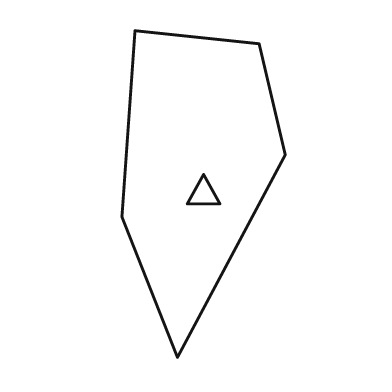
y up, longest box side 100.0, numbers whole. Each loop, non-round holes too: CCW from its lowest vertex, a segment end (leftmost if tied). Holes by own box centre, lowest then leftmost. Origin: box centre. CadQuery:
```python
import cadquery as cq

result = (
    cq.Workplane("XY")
    .moveTo(-8.0, -50.0)
    .lineTo(25.0, 12.0)
    .lineTo(17.0, 46.0)
    .lineTo(-21.0, 50.0)
    .lineTo(-25.0, -7.0)
    .close()
    .moveTo(-5.0, -3.0)
    .lineTo(5.0, -3.0)
    .lineTo(0.0, 6.0)
    .close()
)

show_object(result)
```